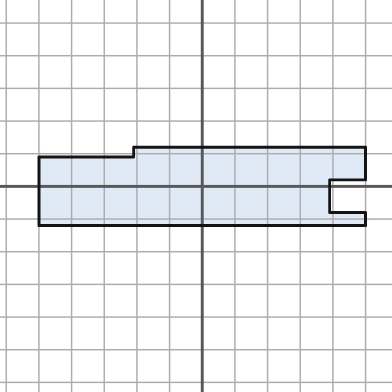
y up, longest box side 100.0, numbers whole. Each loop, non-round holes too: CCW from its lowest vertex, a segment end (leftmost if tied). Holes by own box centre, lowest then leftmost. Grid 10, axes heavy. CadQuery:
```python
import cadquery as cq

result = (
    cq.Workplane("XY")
    .moveTo(-50.0, -12.0)
    .lineTo(50.0, -12.0)
    .lineTo(50.0, -8.0)
    .lineTo(39.0, -8.0)
    .lineTo(39.0, 2.0)
    .lineTo(50.0, 2.0)
    .lineTo(50.0, 12.0)
    .lineTo(-21.0, 12.0)
    .lineTo(-21.0, 9.0)
    .lineTo(-50.0, 9.0)
    .close()
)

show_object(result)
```